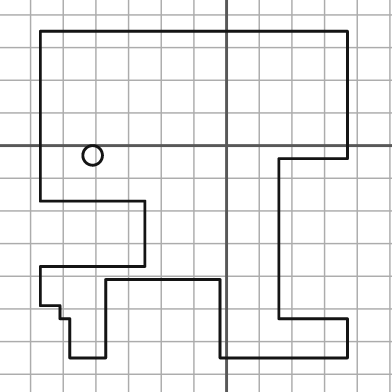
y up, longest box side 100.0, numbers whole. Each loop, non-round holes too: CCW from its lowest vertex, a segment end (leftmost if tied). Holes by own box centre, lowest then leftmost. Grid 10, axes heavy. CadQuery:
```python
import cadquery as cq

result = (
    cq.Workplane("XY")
    .moveTo(-48.0, -65.0)
    .lineTo(-37.0, -65.0)
    .lineTo(-37.0, -41.0)
    .lineTo(-2.0, -41.0)
    .lineTo(-2.0, -65.0)
    .lineTo(37.0, -65.0)
    .lineTo(37.0, -53.0)
    .lineTo(16.0, -53.0)
    .lineTo(16.0, -4.0)
    .lineTo(37.0, -4.0)
    .lineTo(37.0, 35.0)
    .lineTo(-57.0, 35.0)
    .lineTo(-57.0, -17.0)
    .lineTo(-25.0, -17.0)
    .lineTo(-25.0, -37.0)
    .lineTo(-57.0, -37.0)
    .lineTo(-57.0, -49.0)
    .lineTo(-51.0, -49.0)
    .lineTo(-51.0, -53.0)
    .lineTo(-48.0, -53.0)
    .close()
    .moveTo(-41.0, -3.0)
    .circle(3.0)
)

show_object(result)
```